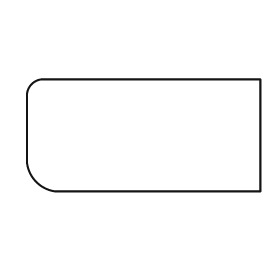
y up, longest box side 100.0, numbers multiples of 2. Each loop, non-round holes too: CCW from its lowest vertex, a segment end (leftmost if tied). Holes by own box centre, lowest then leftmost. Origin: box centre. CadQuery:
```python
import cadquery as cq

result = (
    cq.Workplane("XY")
    .moveTo(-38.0, -24.0)
    .lineTo(50.0, -24.0)
    .lineTo(50.0, 24.0)
    .lineTo(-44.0, 24.0)
    .threePointArc((-48.0, 22.0), (-50.0, 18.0))
    .lineTo(-50.0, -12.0)
    .threePointArc((-46.0, -20.0), (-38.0, -24.0))
    .close()
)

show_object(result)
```